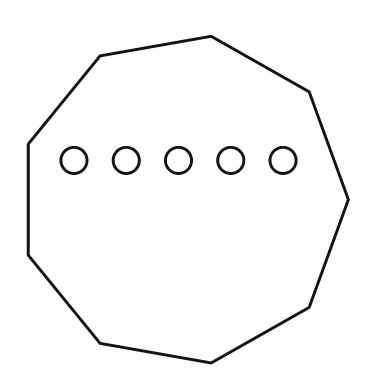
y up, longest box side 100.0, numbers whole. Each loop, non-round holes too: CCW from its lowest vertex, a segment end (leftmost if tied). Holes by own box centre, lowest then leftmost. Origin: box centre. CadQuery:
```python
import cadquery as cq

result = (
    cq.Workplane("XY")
    .moveTo(7.0, -50.0)
    .lineTo(37.0, -33.0)
    .lineTo(49.0, 0.0)
    .lineTo(37.0, 33.0)
    .lineTo(7.0, 50.0)
    .lineTo(-27.0, 44.0)
    .lineTo(-49.0, 17.0)
    .lineTo(-49.0, -17.0)
    .lineTo(-27.0, -44.0)
    .close()
    .moveTo(-35.0, 12.0)
    .circle(4.0)
    .moveTo(-19.0, 12.0)
    .circle(4.0)
    .moveTo(-3.0, 12.0)
    .circle(4.0)
    .moveTo(13.0, 12.0)
    .circle(4.0)
    .moveTo(29.0, 12.0)
    .circle(4.0)
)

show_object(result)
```